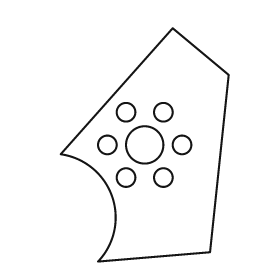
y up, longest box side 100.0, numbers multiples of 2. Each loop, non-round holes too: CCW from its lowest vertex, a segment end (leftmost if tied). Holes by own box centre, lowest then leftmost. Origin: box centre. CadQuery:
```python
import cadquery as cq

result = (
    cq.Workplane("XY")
    .moveTo(-20.0, -50.0)
    .lineTo(28.0, -46.0)
    .lineTo(36.0, 30.0)
    .lineTo(12.0, 50.0)
    .lineTo(-36.0, -4.0)
    .threePointArc((-14.0, -22.0), (-20.0, -50.0))
    .close()
    .moveTo(-8.0, -14.0)
    .circle(4.0)
    .moveTo(8.0, -14.0)
    .circle(4.0)
    .moveTo(-16.0, 0.0)
    .circle(4.0)
    .moveTo(0.0, 0.0)
    .circle(8.0)
    .moveTo(16.0, 0.0)
    .circle(4.0)
    .moveTo(-8.0, 14.0)
    .circle(4.0)
    .moveTo(8.0, 14.0)
    .circle(4.0)
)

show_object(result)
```